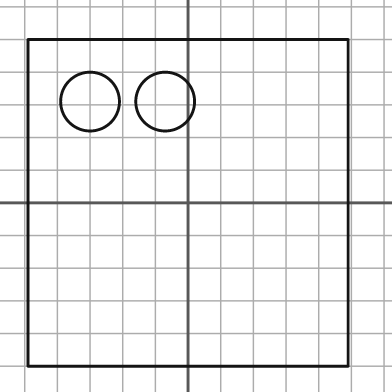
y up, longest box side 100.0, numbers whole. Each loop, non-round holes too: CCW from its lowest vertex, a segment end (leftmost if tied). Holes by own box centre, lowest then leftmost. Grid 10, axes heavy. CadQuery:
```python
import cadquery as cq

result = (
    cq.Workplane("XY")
    .moveTo(-49.0, -50.0)
    .lineTo(49.0, -50.0)
    .lineTo(49.0, 50.0)
    .lineTo(-49.0, 50.0)
    .close()
    .moveTo(-30.0, 31.0)
    .circle(9.0)
    .moveTo(-7.0, 31.0)
    .circle(9.0)
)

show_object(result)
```